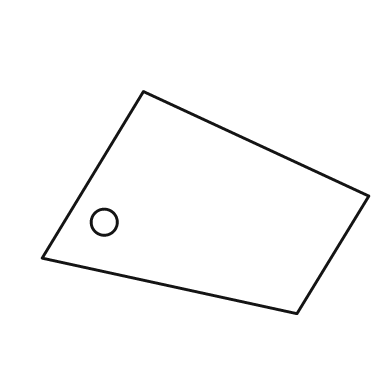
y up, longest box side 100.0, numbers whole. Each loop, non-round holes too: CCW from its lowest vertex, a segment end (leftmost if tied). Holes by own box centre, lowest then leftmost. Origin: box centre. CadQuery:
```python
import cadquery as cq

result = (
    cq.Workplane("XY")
    .moveTo(28.0, -34.0)
    .lineTo(50.0, 2.0)
    .lineTo(-19.0, 34.0)
    .lineTo(-50.0, -17.0)
    .close()
    .moveTo(-31.0, -6.0)
    .circle(4.0)
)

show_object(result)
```